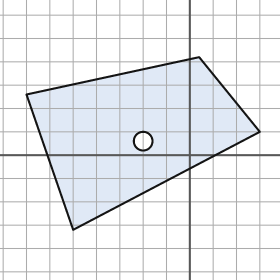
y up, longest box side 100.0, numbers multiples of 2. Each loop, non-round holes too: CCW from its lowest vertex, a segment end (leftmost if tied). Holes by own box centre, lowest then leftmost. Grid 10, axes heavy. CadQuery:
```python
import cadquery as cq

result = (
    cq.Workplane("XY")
    .moveTo(-50.0, -32.0)
    .lineTo(30.0, 10.0)
    .lineTo(4.0, 42.0)
    .lineTo(-70.0, 26.0)
    .close()
    .moveTo(-20.0, 6.0)
    .circle(4.0)
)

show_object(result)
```